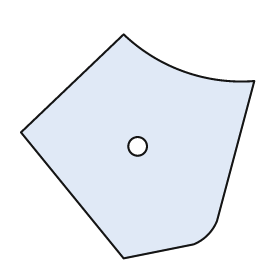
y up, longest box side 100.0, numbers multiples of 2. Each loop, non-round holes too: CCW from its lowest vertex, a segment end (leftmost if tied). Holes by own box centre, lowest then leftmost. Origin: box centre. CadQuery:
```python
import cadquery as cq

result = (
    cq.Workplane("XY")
    .moveTo(-6.0, -48.0)
    .lineTo(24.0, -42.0)
    .threePointArc((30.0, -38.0), (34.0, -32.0))
    .lineTo(50.0, 28.0)
    .threePointArc((20.0, 32.0), (-6.0, 48.0))
    .lineTo(-50.0, 6.0)
    .close()
    .moveTo(0.0, 0.0)
    .circle(4.0)
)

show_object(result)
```